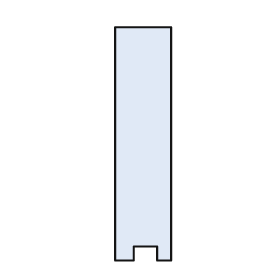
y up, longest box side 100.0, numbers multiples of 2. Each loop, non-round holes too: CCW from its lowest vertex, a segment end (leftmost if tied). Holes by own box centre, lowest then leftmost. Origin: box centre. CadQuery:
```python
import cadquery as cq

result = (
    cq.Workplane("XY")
    .moveTo(-12.0, -50.0)
    .lineTo(-4.0, -50.0)
    .lineTo(-4.0, -44.0)
    .lineTo(6.0, -44.0)
    .lineTo(6.0, -50.0)
    .lineTo(12.0, -50.0)
    .lineTo(12.0, 50.0)
    .lineTo(-12.0, 50.0)
    .close()
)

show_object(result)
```